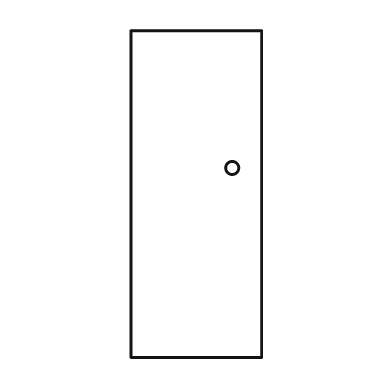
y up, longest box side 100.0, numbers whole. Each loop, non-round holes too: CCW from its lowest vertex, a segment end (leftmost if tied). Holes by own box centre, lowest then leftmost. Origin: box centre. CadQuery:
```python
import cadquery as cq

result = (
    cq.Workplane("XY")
    .moveTo(-20.0, -50.0)
    .lineTo(20.0, -50.0)
    .lineTo(20.0, 50.0)
    .lineTo(-20.0, 50.0)
    .close()
    .moveTo(11.0, 8.0)
    .circle(2.0)
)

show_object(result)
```